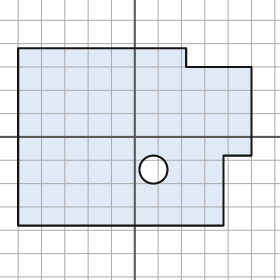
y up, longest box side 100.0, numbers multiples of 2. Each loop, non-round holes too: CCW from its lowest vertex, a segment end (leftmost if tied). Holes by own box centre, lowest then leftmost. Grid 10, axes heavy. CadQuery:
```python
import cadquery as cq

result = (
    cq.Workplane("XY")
    .moveTo(-50.0, -38.0)
    .lineTo(38.0, -38.0)
    .lineTo(38.0, -8.0)
    .lineTo(50.0, -8.0)
    .lineTo(50.0, 30.0)
    .lineTo(22.0, 30.0)
    .lineTo(22.0, 38.0)
    .lineTo(-50.0, 38.0)
    .close()
    .moveTo(8.0, -14.0)
    .circle(6.0)
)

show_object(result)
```